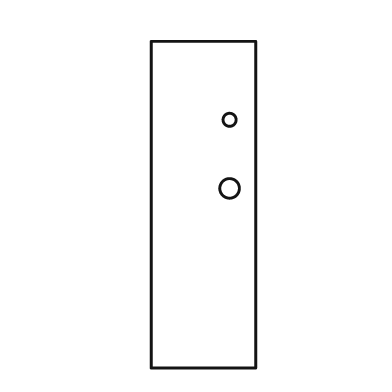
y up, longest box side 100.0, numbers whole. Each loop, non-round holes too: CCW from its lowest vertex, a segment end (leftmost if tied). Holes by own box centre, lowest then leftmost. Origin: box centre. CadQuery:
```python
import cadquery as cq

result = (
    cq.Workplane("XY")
    .moveTo(-16.0, -50.0)
    .lineTo(16.0, -50.0)
    .lineTo(16.0, 50.0)
    .lineTo(-16.0, 50.0)
    .close()
    .moveTo(8.0, 5.0)
    .circle(3.0)
    .moveTo(8.0, 26.0)
    .circle(2.0)
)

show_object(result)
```